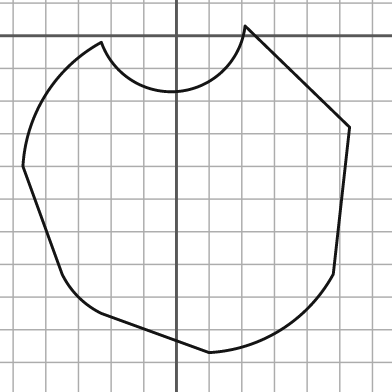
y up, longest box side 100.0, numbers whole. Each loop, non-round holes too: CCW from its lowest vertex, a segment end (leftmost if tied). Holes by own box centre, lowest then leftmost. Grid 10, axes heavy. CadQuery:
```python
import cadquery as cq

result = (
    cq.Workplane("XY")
    .moveTo(10.0, -97.0)
    .threePointArc((32.0, -90.0), (48.0, -73.0))
    .lineTo(53.0, -28.0)
    .lineTo(21.0, 3.0)
    .threePointArc((1.0, -17.0), (-23.0, -2.0))
    .threePointArc((-40.0, -18.0), (-47.0, -40.0))
    .lineTo(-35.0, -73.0)
    .threePointArc((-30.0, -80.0), (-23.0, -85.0))
    .close()
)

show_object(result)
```